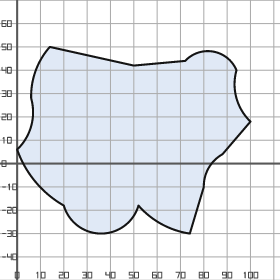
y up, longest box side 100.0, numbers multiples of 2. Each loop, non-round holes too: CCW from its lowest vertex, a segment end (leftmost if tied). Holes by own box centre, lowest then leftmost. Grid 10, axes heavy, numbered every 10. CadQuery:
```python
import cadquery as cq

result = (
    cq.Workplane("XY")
    .moveTo(74.0, -30.0)
    .lineTo(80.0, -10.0)
    .threePointArc((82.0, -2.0), (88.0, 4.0))
    .lineTo(100.0, 18.0)
    .threePointArc((94.0, 28.0), (94.0, 40.0))
    .threePointArc((84.0, 48.0), (72.0, 44.0))
    .lineTo(50.0, 42.0)
    .lineTo(14.0, 50.0)
    .threePointArc((8.0, 40.0), (6.0, 28.0))
    .threePointArc((6.0, 16.0), (0.0, 6.0))
    .threePointArc((8.0, -8.0), (20.0, -18.0))
    .threePointArc((36.0, -30.0), (52.0, -18.0))
    .threePointArc((62.0, -26.0), (74.0, -30.0))
    .close()
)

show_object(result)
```